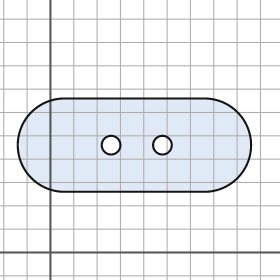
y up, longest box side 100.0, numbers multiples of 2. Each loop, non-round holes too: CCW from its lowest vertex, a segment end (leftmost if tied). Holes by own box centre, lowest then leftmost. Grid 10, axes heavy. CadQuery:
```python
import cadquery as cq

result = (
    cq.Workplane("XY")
    .moveTo(6.0, 26.0)
    .lineTo(66.0, 26.0)
    .threePointArc((86.0, 46.0), (66.0, 66.0))
    .lineTo(6.0, 66.0)
    .threePointArc((-14.0, 46.0), (6.0, 26.0))
    .close()
    .moveTo(26.0, 46.0)
    .circle(4.0)
    .moveTo(48.0, 46.0)
    .circle(4.0)
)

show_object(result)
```